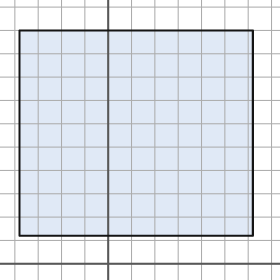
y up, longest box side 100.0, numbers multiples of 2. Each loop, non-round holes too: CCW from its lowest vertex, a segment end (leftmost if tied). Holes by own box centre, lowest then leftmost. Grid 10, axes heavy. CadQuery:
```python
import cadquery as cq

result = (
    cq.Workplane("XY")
    .moveTo(-38.0, 12.0)
    .lineTo(62.0, 12.0)
    .lineTo(62.0, 100.0)
    .lineTo(-38.0, 100.0)
    .close()
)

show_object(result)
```